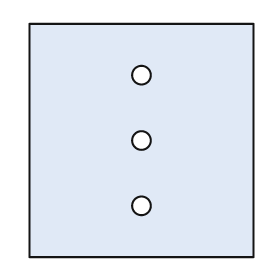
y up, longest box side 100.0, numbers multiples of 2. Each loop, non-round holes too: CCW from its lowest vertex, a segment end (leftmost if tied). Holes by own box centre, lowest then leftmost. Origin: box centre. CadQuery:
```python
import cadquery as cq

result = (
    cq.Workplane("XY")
    .moveTo(-48.0, -50.0)
    .lineTo(48.0, -50.0)
    .lineTo(48.0, 50.0)
    .lineTo(-48.0, 50.0)
    .close()
    .moveTo(0.0, -28.0)
    .circle(4.0)
    .moveTo(0.0, 0.0)
    .circle(4.0)
    .moveTo(0.0, 28.0)
    .circle(4.0)
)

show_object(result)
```